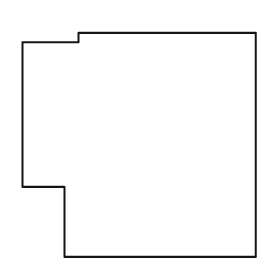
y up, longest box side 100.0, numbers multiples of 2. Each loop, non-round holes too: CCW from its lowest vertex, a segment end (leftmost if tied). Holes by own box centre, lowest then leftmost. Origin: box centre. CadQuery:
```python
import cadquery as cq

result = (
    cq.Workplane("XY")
    .moveTo(-32.0, -48.0)
    .lineTo(50.0, -48.0)
    .lineTo(50.0, 48.0)
    .lineTo(-26.0, 48.0)
    .lineTo(-26.0, 44.0)
    .lineTo(-50.0, 44.0)
    .lineTo(-50.0, -18.0)
    .lineTo(-32.0, -18.0)
    .close()
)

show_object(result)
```